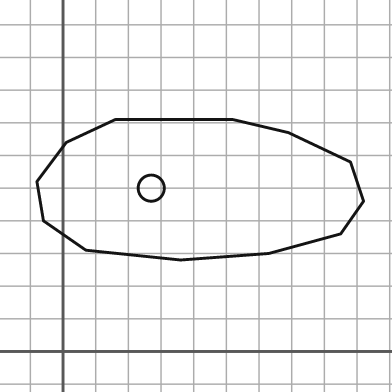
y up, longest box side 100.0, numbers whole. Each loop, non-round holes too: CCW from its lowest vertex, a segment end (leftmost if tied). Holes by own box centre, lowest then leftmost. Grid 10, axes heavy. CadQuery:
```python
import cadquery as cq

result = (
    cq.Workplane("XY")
    .moveTo(36.0, 28.0)
    .lineTo(63.0, 30.0)
    .lineTo(85.0, 36.0)
    .lineTo(92.0, 46.0)
    .lineTo(88.0, 58.0)
    .lineTo(69.0, 67.0)
    .lineTo(52.0, 71.0)
    .lineTo(16.0, 71.0)
    .lineTo(1.0, 64.0)
    .lineTo(-8.0, 52.0)
    .lineTo(-6.0, 40.0)
    .lineTo(7.0, 31.0)
    .close()
    .moveTo(27.0, 50.0)
    .circle(4.0)
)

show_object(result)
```